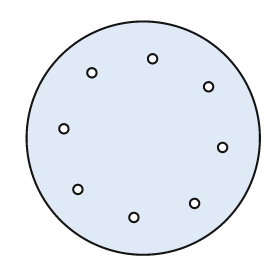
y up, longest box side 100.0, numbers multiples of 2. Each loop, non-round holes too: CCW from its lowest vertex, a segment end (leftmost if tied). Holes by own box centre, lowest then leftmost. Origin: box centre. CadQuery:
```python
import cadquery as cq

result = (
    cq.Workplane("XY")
    .moveTo(0.0, 0.0)
    .circle(50.0)
    .moveTo(-4.0, -34.0)
    .circle(2.0)
    .moveTo(22.0, -28.0)
    .circle(2.0)
    .moveTo(-28.0, -22.0)
    .circle(2.0)
    .moveTo(34.0, -4.0)
    .circle(2.0)
    .moveTo(-34.0, 4.0)
    .circle(2.0)
    .moveTo(28.0, 22.0)
    .circle(2.0)
    .moveTo(-22.0, 28.0)
    .circle(2.0)
    .moveTo(4.0, 34.0)
    .circle(2.0)
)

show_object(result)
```